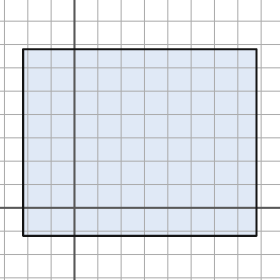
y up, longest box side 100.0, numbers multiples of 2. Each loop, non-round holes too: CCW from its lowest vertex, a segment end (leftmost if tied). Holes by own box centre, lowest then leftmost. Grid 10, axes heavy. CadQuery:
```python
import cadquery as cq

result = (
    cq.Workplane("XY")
    .moveTo(-22.0, -12.0)
    .lineTo(78.0, -12.0)
    .lineTo(78.0, 68.0)
    .lineTo(-22.0, 68.0)
    .close()
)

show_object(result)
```